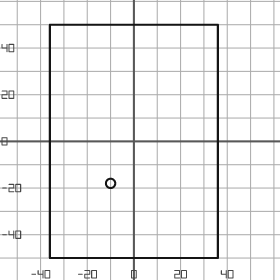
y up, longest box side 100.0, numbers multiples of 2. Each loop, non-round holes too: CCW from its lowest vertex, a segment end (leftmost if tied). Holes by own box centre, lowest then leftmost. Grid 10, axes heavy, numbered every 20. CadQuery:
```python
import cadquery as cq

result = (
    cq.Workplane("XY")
    .moveTo(-36.0, -50.0)
    .lineTo(36.0, -50.0)
    .lineTo(36.0, 50.0)
    .lineTo(-36.0, 50.0)
    .close()
    .moveTo(-10.0, -18.0)
    .circle(2.0)
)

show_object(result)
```